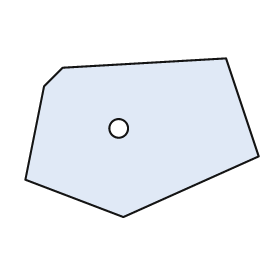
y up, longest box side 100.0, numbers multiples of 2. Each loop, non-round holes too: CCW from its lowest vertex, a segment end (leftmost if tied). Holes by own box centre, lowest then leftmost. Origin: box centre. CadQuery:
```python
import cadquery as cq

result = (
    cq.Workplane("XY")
    .moveTo(-8.0, -34.0)
    .lineTo(50.0, -8.0)
    .lineTo(36.0, 34.0)
    .lineTo(-34.0, 30.0)
    .lineTo(-42.0, 22.0)
    .lineTo(-50.0, -18.0)
    .close()
    .moveTo(-10.0, 4.0)
    .circle(4.0)
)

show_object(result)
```